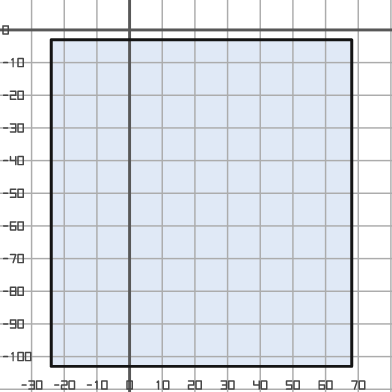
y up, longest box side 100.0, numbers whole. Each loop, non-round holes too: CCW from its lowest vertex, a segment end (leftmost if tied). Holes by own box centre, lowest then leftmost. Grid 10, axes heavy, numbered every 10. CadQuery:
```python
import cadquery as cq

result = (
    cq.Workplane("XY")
    .moveTo(-24.0, -103.0)
    .lineTo(68.0, -103.0)
    .lineTo(68.0, -3.0)
    .lineTo(-24.0, -3.0)
    .close()
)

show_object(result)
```